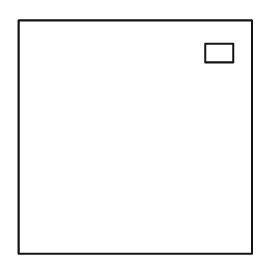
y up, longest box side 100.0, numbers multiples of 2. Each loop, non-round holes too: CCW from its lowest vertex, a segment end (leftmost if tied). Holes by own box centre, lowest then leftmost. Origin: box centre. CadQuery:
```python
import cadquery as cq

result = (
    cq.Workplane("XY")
    .moveTo(-50.0, -50.0)
    .lineTo(50.0, -50.0)
    .lineTo(50.0, 50.0)
    .lineTo(-50.0, 50.0)
    .close()
    .moveTo(30.0, 32.0)
    .lineTo(42.0, 32.0)
    .lineTo(42.0, 40.0)
    .lineTo(30.0, 40.0)
    .close()
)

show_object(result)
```